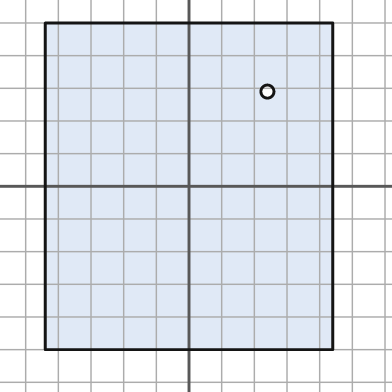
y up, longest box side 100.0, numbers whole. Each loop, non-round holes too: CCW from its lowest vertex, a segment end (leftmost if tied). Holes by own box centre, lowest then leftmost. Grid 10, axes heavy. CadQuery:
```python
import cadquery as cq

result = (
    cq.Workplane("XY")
    .moveTo(-44.0, -50.0)
    .lineTo(44.0, -50.0)
    .lineTo(44.0, 50.0)
    .lineTo(-44.0, 50.0)
    .close()
    .moveTo(24.0, 29.0)
    .circle(2.0)
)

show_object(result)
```